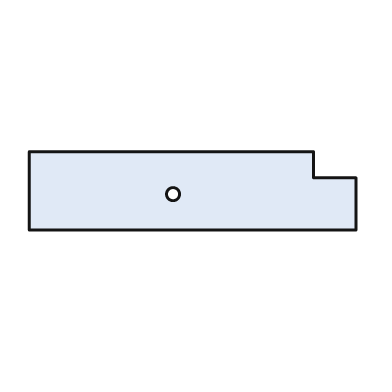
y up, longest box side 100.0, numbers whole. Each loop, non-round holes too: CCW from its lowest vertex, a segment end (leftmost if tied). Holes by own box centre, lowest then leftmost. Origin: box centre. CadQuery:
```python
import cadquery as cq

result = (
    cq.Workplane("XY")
    .moveTo(-50.0, -12.0)
    .lineTo(50.0, -12.0)
    .lineTo(50.0, 4.0)
    .lineTo(37.0, 4.0)
    .lineTo(37.0, 12.0)
    .lineTo(-50.0, 12.0)
    .close()
    .moveTo(-6.0, -1.0)
    .circle(2.0)
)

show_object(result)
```